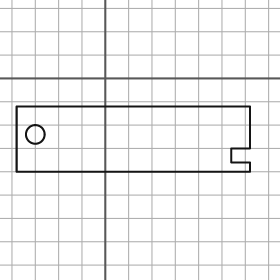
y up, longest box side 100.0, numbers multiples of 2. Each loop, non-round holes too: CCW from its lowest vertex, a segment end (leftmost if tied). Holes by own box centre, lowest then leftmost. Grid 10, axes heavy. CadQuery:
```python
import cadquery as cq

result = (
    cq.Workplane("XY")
    .moveTo(-38.0, -40.0)
    .lineTo(62.0, -40.0)
    .lineTo(62.0, -36.0)
    .lineTo(54.0, -36.0)
    .lineTo(54.0, -30.0)
    .lineTo(62.0, -30.0)
    .lineTo(62.0, -12.0)
    .lineTo(-38.0, -12.0)
    .close()
    .moveTo(-30.0, -24.0)
    .circle(4.0)
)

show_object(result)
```